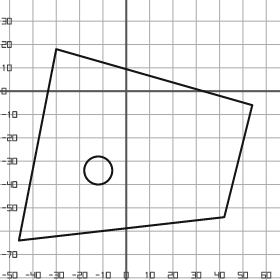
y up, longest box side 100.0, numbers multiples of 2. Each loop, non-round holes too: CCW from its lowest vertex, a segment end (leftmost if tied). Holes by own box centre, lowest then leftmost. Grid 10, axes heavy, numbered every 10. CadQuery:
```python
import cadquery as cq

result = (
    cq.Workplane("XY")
    .moveTo(-46.0, -64.0)
    .lineTo(42.0, -54.0)
    .lineTo(54.0, -6.0)
    .lineTo(-30.0, 18.0)
    .close()
    .moveTo(-12.0, -34.0)
    .circle(6.0)
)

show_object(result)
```